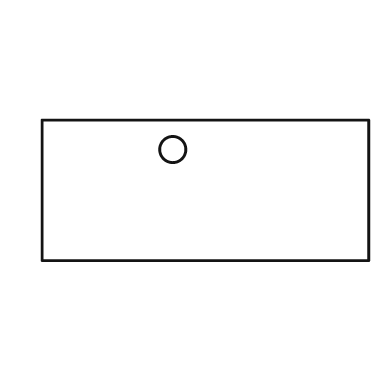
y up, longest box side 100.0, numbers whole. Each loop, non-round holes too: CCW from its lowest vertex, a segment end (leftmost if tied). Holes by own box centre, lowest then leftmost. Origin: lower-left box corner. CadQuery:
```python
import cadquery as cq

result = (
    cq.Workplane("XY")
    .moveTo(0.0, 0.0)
    .lineTo(100.0, 0.0)
    .lineTo(100.0, 43.0)
    .lineTo(0.0, 43.0)
    .close()
    .moveTo(40.0, 34.0)
    .circle(4.0)
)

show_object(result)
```